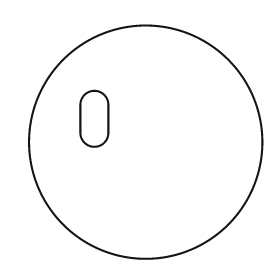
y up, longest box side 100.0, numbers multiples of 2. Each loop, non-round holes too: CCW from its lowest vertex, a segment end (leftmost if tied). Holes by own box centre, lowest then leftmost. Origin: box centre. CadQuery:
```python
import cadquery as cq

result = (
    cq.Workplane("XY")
    .moveTo(0.0, 0.0)
    .circle(50.0)
    .moveTo(-28.0, 4.0)
    .threePointArc((-22.0, -2.0), (-16.0, 4.0))
    .lineTo(-16.0, 16.0)
    .threePointArc((-22.0, 22.0), (-28.0, 16.0))
    .close()
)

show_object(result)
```